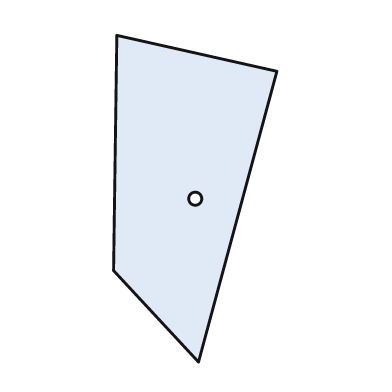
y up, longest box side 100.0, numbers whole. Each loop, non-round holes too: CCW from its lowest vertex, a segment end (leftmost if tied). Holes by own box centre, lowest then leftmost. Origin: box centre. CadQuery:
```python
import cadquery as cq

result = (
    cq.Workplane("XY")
    .moveTo(1.0, -50.0)
    .lineTo(25.0, 39.0)
    .lineTo(-24.0, 50.0)
    .lineTo(-25.0, -22.0)
    .close()
    .moveTo(0.0, 0.0)
    .circle(2.0)
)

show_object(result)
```